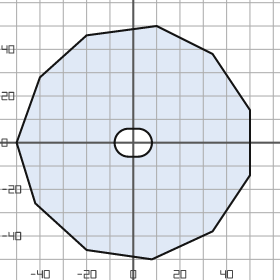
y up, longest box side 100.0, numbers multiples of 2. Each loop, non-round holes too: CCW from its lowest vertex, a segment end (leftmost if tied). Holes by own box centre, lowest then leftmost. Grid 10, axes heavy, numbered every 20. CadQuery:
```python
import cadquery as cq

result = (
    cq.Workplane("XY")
    .moveTo(8.0, -50.0)
    .lineTo(34.0, -38.0)
    .lineTo(50.0, -14.0)
    .lineTo(50.0, 14.0)
    .lineTo(34.0, 38.0)
    .lineTo(10.0, 50.0)
    .lineTo(-20.0, 46.0)
    .lineTo(-40.0, 28.0)
    .lineTo(-50.0, 0.0)
    .lineTo(-42.0, -26.0)
    .lineTo(-20.0, -46.0)
    .close()
    .moveTo(-2.0, -6.0)
    .lineTo(2.0, -6.0)
    .threePointArc((8.0, 0.0), (2.0, 6.0))
    .lineTo(-2.0, 6.0)
    .threePointArc((-8.0, 0.0), (-2.0, -6.0))
    .close()
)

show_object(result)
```